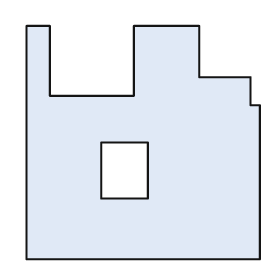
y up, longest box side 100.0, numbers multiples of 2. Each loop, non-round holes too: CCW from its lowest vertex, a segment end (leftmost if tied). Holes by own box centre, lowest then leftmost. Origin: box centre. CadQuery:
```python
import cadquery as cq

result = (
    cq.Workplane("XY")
    .moveTo(-50.0, -50.0)
    .lineTo(50.0, -50.0)
    .lineTo(50.0, 16.0)
    .lineTo(46.0, 16.0)
    .lineTo(46.0, 28.0)
    .lineTo(24.0, 28.0)
    .lineTo(24.0, 50.0)
    .lineTo(-4.0, 50.0)
    .lineTo(-4.0, 20.0)
    .lineTo(-40.0, 20.0)
    .lineTo(-40.0, 50.0)
    .lineTo(-50.0, 50.0)
    .close()
    .moveTo(-18.0, -24.0)
    .lineTo(2.0, -24.0)
    .lineTo(2.0, 0.0)
    .lineTo(-18.0, 0.0)
    .close()
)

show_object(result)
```